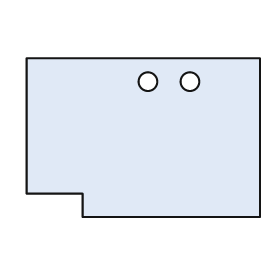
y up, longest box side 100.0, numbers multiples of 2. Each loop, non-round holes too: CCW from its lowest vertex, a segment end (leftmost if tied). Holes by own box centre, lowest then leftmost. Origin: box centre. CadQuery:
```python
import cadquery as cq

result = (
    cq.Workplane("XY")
    .moveTo(-26.0, -34.0)
    .lineTo(50.0, -34.0)
    .lineTo(50.0, 34.0)
    .lineTo(-50.0, 34.0)
    .lineTo(-50.0, -24.0)
    .lineTo(-26.0, -24.0)
    .close()
    .moveTo(2.0, 24.0)
    .circle(4.0)
    .moveTo(20.0, 24.0)
    .circle(4.0)
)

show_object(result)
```